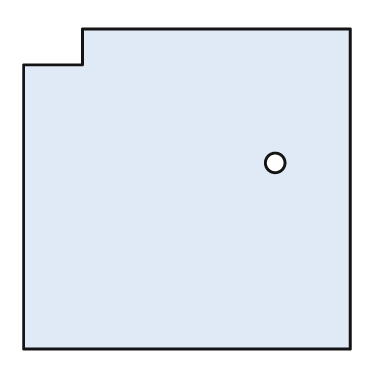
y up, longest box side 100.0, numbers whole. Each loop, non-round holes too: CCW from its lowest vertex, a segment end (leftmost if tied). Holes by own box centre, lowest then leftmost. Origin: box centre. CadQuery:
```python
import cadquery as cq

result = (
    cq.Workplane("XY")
    .moveTo(-50.0, -49.0)
    .lineTo(50.0, -49.0)
    .lineTo(50.0, 49.0)
    .lineTo(-32.0, 49.0)
    .lineTo(-32.0, 38.0)
    .lineTo(-50.0, 38.0)
    .close()
    .moveTo(27.0, 8.0)
    .circle(3.0)
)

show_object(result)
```